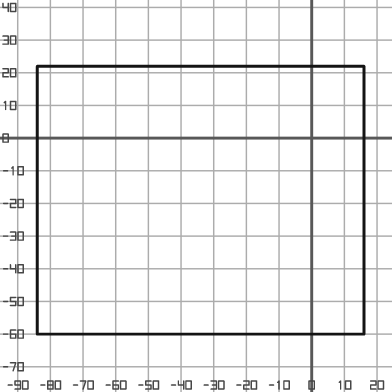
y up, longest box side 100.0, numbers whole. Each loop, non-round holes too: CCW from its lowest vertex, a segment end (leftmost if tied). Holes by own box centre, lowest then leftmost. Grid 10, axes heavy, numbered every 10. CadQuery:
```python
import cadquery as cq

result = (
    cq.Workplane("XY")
    .moveTo(-84.0, -60.0)
    .lineTo(16.0, -60.0)
    .lineTo(16.0, 22.0)
    .lineTo(-84.0, 22.0)
    .close()
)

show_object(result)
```